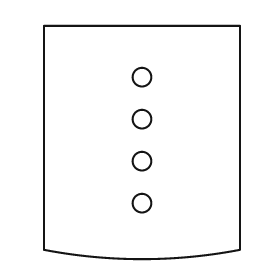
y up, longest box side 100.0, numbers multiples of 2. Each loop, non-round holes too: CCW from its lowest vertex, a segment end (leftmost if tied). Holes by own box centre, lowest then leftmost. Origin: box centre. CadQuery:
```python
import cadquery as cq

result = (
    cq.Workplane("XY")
    .moveTo(-42.0, -46.0)
    .threePointArc((0.0, -50.0), (42.0, -46.0))
    .lineTo(42.0, 50.0)
    .lineTo(-42.0, 50.0)
    .close()
    .moveTo(0.0, -26.0)
    .circle(4.0)
    .moveTo(0.0, -8.0)
    .circle(4.0)
    .moveTo(0.0, 10.0)
    .circle(4.0)
    .moveTo(0.0, 28.0)
    .circle(4.0)
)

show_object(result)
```